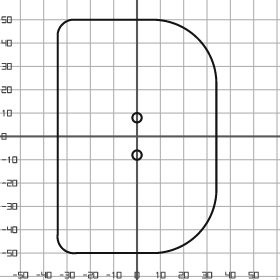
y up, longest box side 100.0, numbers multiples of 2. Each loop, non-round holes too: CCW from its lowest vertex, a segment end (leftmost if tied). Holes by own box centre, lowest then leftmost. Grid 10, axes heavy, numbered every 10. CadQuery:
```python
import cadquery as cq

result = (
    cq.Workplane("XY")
    .moveTo(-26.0, -50.0)
    .lineTo(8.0, -50.0)
    .threePointArc((26.0, -42.0), (34.0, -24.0))
    .lineTo(34.0, 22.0)
    .threePointArc((26.0, 42.0), (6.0, 50.0))
    .lineTo(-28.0, 50.0)
    .threePointArc((-32.0, 48.0), (-34.0, 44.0))
    .lineTo(-34.0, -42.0)
    .threePointArc((-32.0, -48.0), (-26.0, -50.0))
    .close()
    .moveTo(0.0, -8.0)
    .circle(2.0)
    .moveTo(0.0, 8.0)
    .circle(2.0)
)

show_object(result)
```